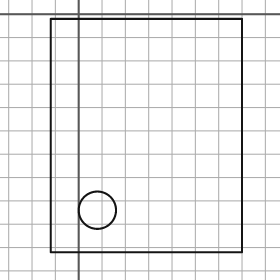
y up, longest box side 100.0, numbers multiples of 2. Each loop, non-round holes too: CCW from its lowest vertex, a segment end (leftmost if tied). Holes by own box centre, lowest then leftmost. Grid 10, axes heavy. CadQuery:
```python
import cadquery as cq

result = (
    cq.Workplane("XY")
    .moveTo(-12.0, -102.0)
    .lineTo(70.0, -102.0)
    .lineTo(70.0, -2.0)
    .lineTo(-12.0, -2.0)
    .close()
    .moveTo(8.0, -84.0)
    .circle(8.0)
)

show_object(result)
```